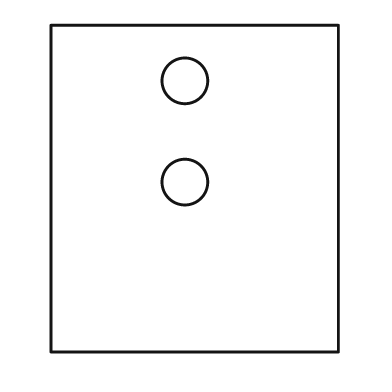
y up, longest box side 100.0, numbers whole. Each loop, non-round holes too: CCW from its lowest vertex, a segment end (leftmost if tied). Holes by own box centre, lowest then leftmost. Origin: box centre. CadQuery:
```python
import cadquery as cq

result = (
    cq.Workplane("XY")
    .moveTo(-44.0, -50.0)
    .lineTo(44.0, -50.0)
    .lineTo(44.0, 50.0)
    .lineTo(-44.0, 50.0)
    .close()
    .moveTo(-3.0, 2.0)
    .circle(7.0)
    .moveTo(-3.0, 33.0)
    .circle(7.0)
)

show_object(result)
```